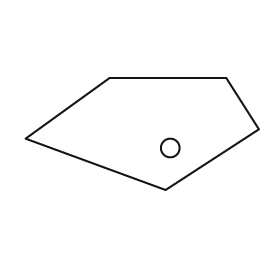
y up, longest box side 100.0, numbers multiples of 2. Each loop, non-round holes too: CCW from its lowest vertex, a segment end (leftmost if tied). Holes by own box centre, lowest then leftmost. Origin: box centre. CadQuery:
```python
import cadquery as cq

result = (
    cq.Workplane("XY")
    .moveTo(10.0, -24.0)
    .lineTo(50.0, 2.0)
    .lineTo(36.0, 24.0)
    .lineTo(-14.0, 24.0)
    .lineTo(-50.0, -2.0)
    .close()
    .moveTo(12.0, -6.0)
    .circle(4.0)
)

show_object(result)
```